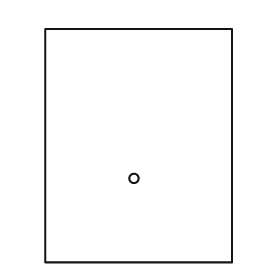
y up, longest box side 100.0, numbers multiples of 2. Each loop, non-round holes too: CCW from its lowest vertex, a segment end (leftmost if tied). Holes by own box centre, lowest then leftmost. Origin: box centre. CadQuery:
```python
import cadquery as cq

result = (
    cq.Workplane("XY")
    .moveTo(-40.0, -50.0)
    .lineTo(40.0, -50.0)
    .lineTo(40.0, 50.0)
    .lineTo(-40.0, 50.0)
    .close()
    .moveTo(-2.0, -14.0)
    .circle(2.0)
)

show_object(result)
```